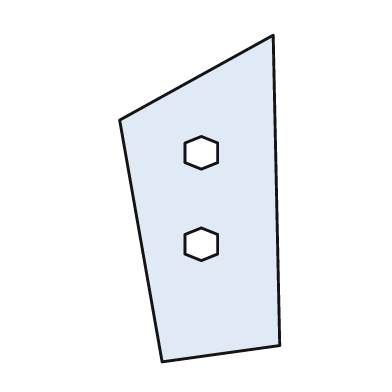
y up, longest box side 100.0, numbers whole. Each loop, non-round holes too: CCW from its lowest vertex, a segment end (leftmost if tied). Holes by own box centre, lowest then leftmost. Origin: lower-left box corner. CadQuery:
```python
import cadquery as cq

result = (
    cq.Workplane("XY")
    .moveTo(13.0, 0.0)
    .lineTo(49.0, 5.0)
    .lineTo(47.0, 100.0)
    .lineTo(0.0, 74.0)
    .close()
    .moveTo(25.0, 31.0)
    .lineTo(30.0, 33.0)
    .lineTo(30.0, 39.0)
    .lineTo(25.0, 41.0)
    .lineTo(20.0, 39.0)
    .lineTo(20.0, 33.0)
    .close()
    .moveTo(25.0, 59.0)
    .lineTo(30.0, 61.0)
    .lineTo(30.0, 67.0)
    .lineTo(25.0, 69.0)
    .lineTo(20.0, 67.0)
    .lineTo(20.0, 61.0)
    .close()
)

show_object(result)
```